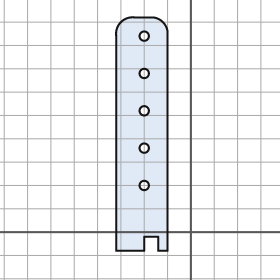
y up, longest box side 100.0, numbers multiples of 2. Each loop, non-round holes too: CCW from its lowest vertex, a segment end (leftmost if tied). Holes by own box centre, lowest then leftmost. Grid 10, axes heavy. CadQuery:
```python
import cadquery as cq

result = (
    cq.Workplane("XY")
    .moveTo(-32.0, -8.0)
    .lineTo(-20.0, -8.0)
    .lineTo(-20.0, -2.0)
    .lineTo(-14.0, -2.0)
    .lineTo(-14.0, -8.0)
    .lineTo(-10.0, -8.0)
    .lineTo(-10.0, 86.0)
    .threePointArc((-12.0, 90.0), (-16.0, 92.0))
    .lineTo(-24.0, 92.0)
    .threePointArc((-30.0, 90.0), (-32.0, 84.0))
    .close()
    .moveTo(-20.0, 20.0)
    .circle(2.0)
    .moveTo(-20.0, 36.0)
    .circle(2.0)
    .moveTo(-20.0, 52.0)
    .circle(2.0)
    .moveTo(-20.0, 68.0)
    .circle(2.0)
    .moveTo(-20.0, 84.0)
    .circle(2.0)
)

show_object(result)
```